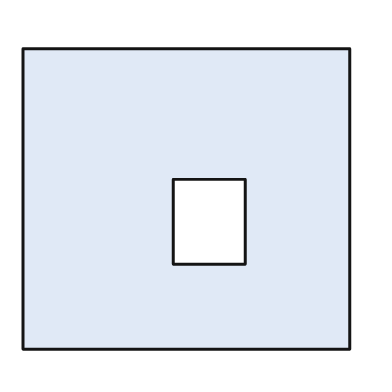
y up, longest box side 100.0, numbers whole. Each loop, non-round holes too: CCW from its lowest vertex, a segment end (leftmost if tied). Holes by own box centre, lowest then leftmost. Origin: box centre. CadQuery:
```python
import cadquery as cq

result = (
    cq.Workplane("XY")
    .moveTo(-50.0, -46.0)
    .lineTo(50.0, -46.0)
    .lineTo(50.0, 46.0)
    .lineTo(-50.0, 46.0)
    .close()
    .moveTo(-4.0, -20.0)
    .lineTo(18.0, -20.0)
    .lineTo(18.0, 6.0)
    .lineTo(-4.0, 6.0)
    .close()
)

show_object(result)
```